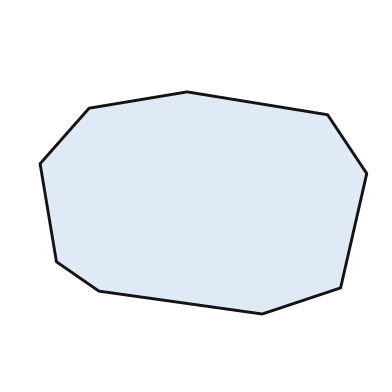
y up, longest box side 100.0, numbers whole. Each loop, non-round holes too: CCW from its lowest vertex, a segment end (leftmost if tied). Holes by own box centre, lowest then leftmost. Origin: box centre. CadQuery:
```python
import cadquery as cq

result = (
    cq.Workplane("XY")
    .moveTo(18.0, -34.0)
    .lineTo(42.0, -26.0)
    .lineTo(50.0, 9.0)
    .lineTo(38.0, 27.0)
    .lineTo(-5.0, 34.0)
    .lineTo(-35.0, 29.0)
    .lineTo(-50.0, 12.0)
    .lineTo(-45.0, -18.0)
    .lineTo(-32.0, -27.0)
    .close()
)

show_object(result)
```